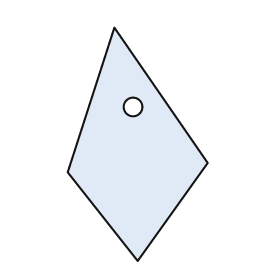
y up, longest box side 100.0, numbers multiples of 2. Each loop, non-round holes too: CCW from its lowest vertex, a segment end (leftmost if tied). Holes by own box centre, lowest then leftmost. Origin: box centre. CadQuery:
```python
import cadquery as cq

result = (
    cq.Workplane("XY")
    .moveTo(0.0, -50.0)
    .lineTo(30.0, -8.0)
    .lineTo(-10.0, 50.0)
    .lineTo(-30.0, -12.0)
    .close()
    .moveTo(-2.0, 16.0)
    .circle(4.0)
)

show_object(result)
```